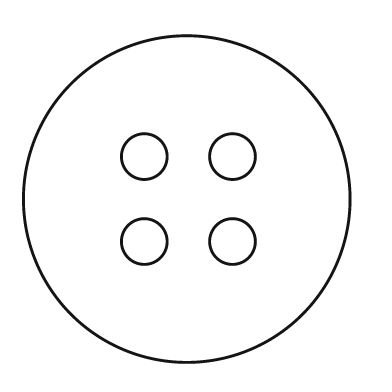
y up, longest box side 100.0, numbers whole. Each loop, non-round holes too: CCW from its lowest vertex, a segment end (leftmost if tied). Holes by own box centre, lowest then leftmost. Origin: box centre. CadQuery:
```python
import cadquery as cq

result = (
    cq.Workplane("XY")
    .moveTo(0.0, 0.0)
    .circle(50.0)
    .moveTo(-13.0, -13.0)
    .circle(7.0)
    .moveTo(14.0, -13.0)
    .circle(7.0)
    .moveTo(-13.0, 13.0)
    .circle(7.0)
    .moveTo(14.0, 13.0)
    .circle(7.0)
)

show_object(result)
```